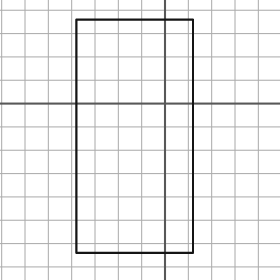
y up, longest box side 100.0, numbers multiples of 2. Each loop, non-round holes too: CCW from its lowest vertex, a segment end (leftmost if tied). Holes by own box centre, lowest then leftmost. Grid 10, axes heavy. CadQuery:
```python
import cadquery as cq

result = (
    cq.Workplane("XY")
    .moveTo(-38.0, -64.0)
    .lineTo(12.0, -64.0)
    .lineTo(12.0, 36.0)
    .lineTo(-38.0, 36.0)
    .close()
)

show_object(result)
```